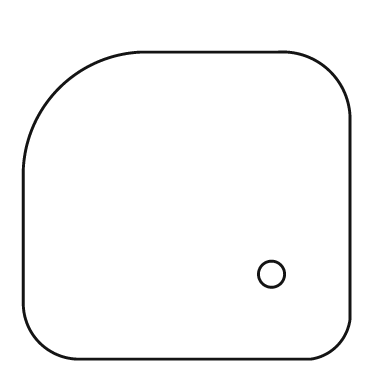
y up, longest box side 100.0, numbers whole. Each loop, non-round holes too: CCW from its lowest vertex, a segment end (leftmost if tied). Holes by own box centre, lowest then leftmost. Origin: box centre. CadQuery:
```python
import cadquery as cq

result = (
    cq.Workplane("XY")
    .moveTo(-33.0, -47.0)
    .lineTo(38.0, -47.0)
    .threePointArc((46.0, -43.0), (50.0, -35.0))
    .lineTo(50.0, 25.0)
    .threePointArc((44.0, 41.0), (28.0, 47.0))
    .lineTo(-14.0, 47.0)
    .threePointArc((-39.0, 36.0), (-50.0, 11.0))
    .lineTo(-50.0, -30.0)
    .threePointArc((-45.0, -42.0), (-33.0, -47.0))
    .close()
    .moveTo(26.0, -21.0)
    .circle(4.0)
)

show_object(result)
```